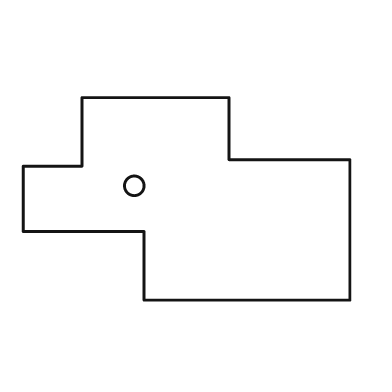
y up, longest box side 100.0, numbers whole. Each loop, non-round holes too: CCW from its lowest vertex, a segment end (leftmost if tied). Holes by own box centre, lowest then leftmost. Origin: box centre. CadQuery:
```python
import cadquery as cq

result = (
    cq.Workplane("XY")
    .moveTo(-13.0, -31.0)
    .lineTo(50.0, -31.0)
    .lineTo(50.0, 12.0)
    .lineTo(13.0, 12.0)
    .lineTo(13.0, 31.0)
    .lineTo(-32.0, 31.0)
    .lineTo(-32.0, 10.0)
    .lineTo(-50.0, 10.0)
    .lineTo(-50.0, -10.0)
    .lineTo(-13.0, -10.0)
    .close()
    .moveTo(-16.0, 4.0)
    .circle(3.0)
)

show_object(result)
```